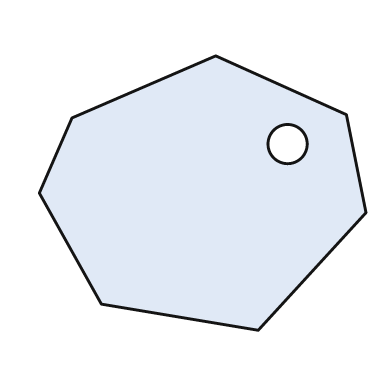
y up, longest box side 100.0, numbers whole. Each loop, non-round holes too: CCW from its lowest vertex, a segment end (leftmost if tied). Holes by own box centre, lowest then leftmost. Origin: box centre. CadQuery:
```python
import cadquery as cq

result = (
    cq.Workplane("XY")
    .moveTo(17.0, -42.0)
    .lineTo(50.0, -6.0)
    .lineTo(44.0, 24.0)
    .lineTo(4.0, 42.0)
    .lineTo(-40.0, 23.0)
    .lineTo(-50.0, 0.0)
    .lineTo(-31.0, -34.0)
    .close()
    .moveTo(26.0, 15.0)
    .circle(6.0)
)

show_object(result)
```